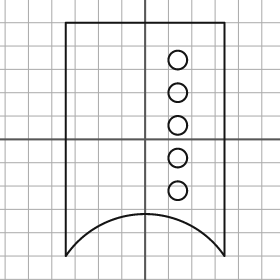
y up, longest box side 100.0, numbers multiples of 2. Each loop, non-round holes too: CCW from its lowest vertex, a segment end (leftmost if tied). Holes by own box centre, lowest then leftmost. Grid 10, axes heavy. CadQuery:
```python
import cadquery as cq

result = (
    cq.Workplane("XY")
    .moveTo(-34.0, -50.0)
    .threePointArc((0.0, -32.0), (34.0, -50.0))
    .lineTo(34.0, 50.0)
    .lineTo(-34.0, 50.0)
    .close()
    .moveTo(14.0, -22.0)
    .circle(4.0)
    .moveTo(14.0, -8.0)
    .circle(4.0)
    .moveTo(14.0, 6.0)
    .circle(4.0)
    .moveTo(14.0, 20.0)
    .circle(4.0)
    .moveTo(14.0, 34.0)
    .circle(4.0)
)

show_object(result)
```